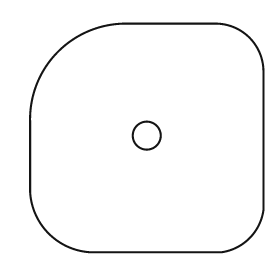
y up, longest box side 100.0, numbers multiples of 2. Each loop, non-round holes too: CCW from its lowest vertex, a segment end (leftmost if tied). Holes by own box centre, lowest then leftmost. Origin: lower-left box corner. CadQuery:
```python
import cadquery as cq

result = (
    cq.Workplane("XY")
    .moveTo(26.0, 0.0)
    .lineTo(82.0, 0.0)
    .threePointArc((94.0, 6.0), (100.0, 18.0))
    .lineTo(100.0, 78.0)
    .threePointArc((94.0, 92.0), (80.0, 98.0))
    .lineTo(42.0, 98.0)
    .threePointArc((12.0, 86.0), (0.0, 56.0))
    .lineTo(0.0, 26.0)
    .threePointArc((8.0, 8.0), (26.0, 0.0))
    .close()
    .moveTo(50.0, 50.0)
    .circle(6.0)
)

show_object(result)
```